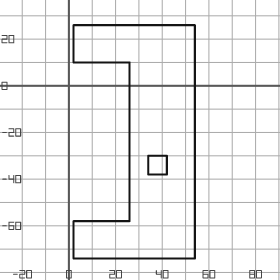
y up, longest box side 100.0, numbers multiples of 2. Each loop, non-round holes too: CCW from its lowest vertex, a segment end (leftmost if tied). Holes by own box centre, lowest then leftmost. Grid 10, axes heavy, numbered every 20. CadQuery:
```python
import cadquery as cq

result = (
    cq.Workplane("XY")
    .moveTo(2.0, -74.0)
    .lineTo(54.0, -74.0)
    .lineTo(54.0, 26.0)
    .lineTo(2.0, 26.0)
    .lineTo(2.0, 10.0)
    .lineTo(26.0, 10.0)
    .lineTo(26.0, -58.0)
    .lineTo(2.0, -58.0)
    .close()
    .moveTo(34.0, -38.0)
    .lineTo(42.0, -38.0)
    .lineTo(42.0, -30.0)
    .lineTo(34.0, -30.0)
    .close()
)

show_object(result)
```